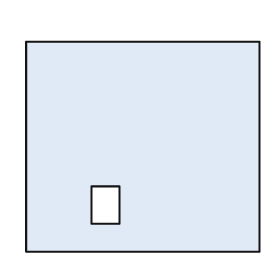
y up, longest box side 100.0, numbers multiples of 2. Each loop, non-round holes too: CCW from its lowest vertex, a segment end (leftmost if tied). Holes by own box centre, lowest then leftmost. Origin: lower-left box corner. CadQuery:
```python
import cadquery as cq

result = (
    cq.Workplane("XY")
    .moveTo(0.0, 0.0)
    .lineTo(100.0, 0.0)
    .lineTo(100.0, 90.0)
    .lineTo(0.0, 90.0)
    .close()
    .moveTo(28.0, 12.0)
    .lineTo(40.0, 12.0)
    .lineTo(40.0, 28.0)
    .lineTo(28.0, 28.0)
    .close()
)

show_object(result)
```